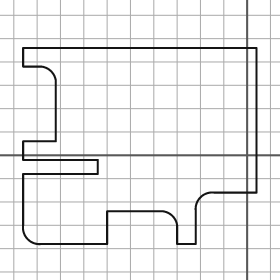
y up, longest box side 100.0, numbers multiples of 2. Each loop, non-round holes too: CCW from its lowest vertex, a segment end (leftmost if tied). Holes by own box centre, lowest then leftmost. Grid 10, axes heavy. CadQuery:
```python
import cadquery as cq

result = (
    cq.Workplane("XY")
    .moveTo(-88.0, -38.0)
    .lineTo(-60.0, -38.0)
    .lineTo(-60.0, -24.0)
    .lineTo(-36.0, -24.0)
    .threePointArc((-32.0, -26.0), (-30.0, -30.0))
    .lineTo(-30.0, -38.0)
    .lineTo(-22.0, -38.0)
    .lineTo(-22.0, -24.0)
    .threePointArc((-20.0, -18.0), (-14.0, -16.0))
    .lineTo(4.0, -16.0)
    .lineTo(4.0, 46.0)
    .lineTo(-96.0, 46.0)
    .lineTo(-96.0, 38.0)
    .lineTo(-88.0, 38.0)
    .threePointArc((-84.0, 36.0), (-82.0, 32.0))
    .lineTo(-82.0, 6.0)
    .lineTo(-96.0, 6.0)
    .lineTo(-96.0, -2.0)
    .lineTo(-64.0, -2.0)
    .lineTo(-64.0, -8.0)
    .lineTo(-96.0, -8.0)
    .lineTo(-96.0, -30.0)
    .threePointArc((-94.0, -36.0), (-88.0, -38.0))
    .close()
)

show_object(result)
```